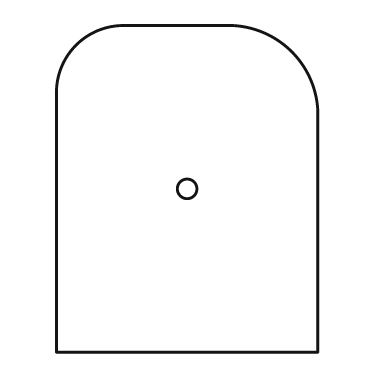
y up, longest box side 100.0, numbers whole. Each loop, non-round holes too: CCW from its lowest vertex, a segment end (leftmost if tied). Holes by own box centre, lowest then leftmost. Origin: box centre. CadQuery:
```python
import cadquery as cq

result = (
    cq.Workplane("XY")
    .moveTo(-40.0, -50.0)
    .lineTo(40.0, -50.0)
    .lineTo(40.0, 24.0)
    .threePointArc((32.0, 42.0), (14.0, 50.0))
    .lineTo(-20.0, 50.0)
    .threePointArc((-34.0, 44.0), (-40.0, 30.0))
    .close()
    .moveTo(0.0, 0.0)
    .circle(3.0)
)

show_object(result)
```